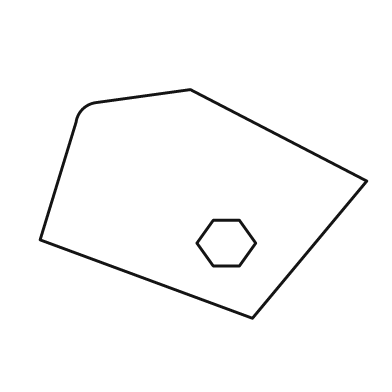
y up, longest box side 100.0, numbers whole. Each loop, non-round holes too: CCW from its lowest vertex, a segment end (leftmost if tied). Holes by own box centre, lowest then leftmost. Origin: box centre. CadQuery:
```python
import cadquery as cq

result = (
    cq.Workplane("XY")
    .moveTo(15.0, -35.0)
    .lineTo(50.0, 7.0)
    .lineTo(-4.0, 35.0)
    .lineTo(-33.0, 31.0)
    .threePointArc((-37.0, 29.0), (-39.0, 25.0))
    .lineTo(-50.0, -11.0)
    .close()
    .moveTo(3.0, -19.0)
    .lineTo(11.0, -19.0)
    .lineTo(16.0, -12.0)
    .lineTo(11.0, -5.0)
    .lineTo(3.0, -5.0)
    .lineTo(-2.0, -12.0)
    .close()
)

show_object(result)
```